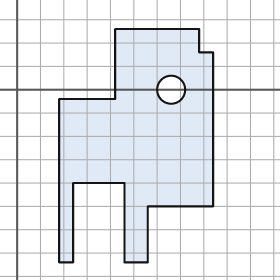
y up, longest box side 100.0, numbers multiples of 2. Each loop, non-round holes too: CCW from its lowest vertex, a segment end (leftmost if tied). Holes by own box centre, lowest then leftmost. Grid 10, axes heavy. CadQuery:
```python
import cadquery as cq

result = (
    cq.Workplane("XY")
    .moveTo(18.0, -74.0)
    .lineTo(24.0, -74.0)
    .lineTo(24.0, -40.0)
    .lineTo(46.0, -40.0)
    .lineTo(46.0, -74.0)
    .lineTo(56.0, -74.0)
    .lineTo(56.0, -50.0)
    .lineTo(84.0, -50.0)
    .lineTo(84.0, 16.0)
    .lineTo(78.0, 16.0)
    .lineTo(78.0, 26.0)
    .lineTo(42.0, 26.0)
    .lineTo(42.0, -4.0)
    .lineTo(18.0, -4.0)
    .close()
    .moveTo(66.0, 0.0)
    .circle(6.0)
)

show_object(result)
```